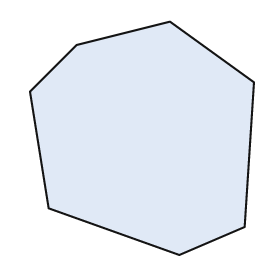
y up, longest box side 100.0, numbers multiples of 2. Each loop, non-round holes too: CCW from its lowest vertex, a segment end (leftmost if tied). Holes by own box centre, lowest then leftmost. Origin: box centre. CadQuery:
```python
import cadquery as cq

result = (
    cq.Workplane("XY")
    .moveTo(16.0, -50.0)
    .lineTo(44.0, -38.0)
    .lineTo(48.0, 24.0)
    .lineTo(12.0, 50.0)
    .lineTo(-28.0, 40.0)
    .lineTo(-48.0, 20.0)
    .lineTo(-40.0, -30.0)
    .close()
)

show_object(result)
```